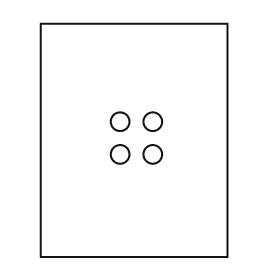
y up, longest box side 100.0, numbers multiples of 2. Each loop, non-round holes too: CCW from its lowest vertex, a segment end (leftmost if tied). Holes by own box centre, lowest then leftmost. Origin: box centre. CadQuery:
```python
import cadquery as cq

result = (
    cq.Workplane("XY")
    .moveTo(-40.0, -50.0)
    .lineTo(40.0, -50.0)
    .lineTo(40.0, 50.0)
    .lineTo(-40.0, 50.0)
    .close()
    .moveTo(-6.0, -6.0)
    .circle(4.0)
    .moveTo(8.0, -6.0)
    .circle(4.0)
    .moveTo(-6.0, 8.0)
    .circle(4.0)
    .moveTo(8.0, 8.0)
    .circle(4.0)
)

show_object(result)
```